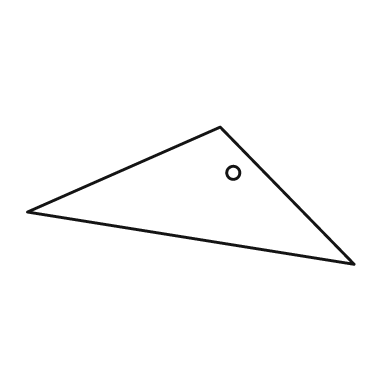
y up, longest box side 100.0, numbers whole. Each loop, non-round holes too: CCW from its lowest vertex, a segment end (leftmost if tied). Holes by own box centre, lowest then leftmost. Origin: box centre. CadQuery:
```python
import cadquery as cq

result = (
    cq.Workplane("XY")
    .moveTo(50.0, -21.0)
    .lineTo(9.0, 21.0)
    .lineTo(-50.0, -5.0)
    .close()
    .moveTo(13.0, 7.0)
    .circle(2.0)
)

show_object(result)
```